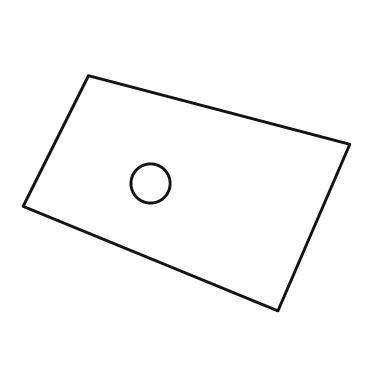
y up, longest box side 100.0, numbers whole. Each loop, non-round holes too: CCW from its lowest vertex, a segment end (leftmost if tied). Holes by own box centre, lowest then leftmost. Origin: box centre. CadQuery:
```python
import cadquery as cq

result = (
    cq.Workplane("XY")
    .moveTo(28.0, -36.0)
    .lineTo(50.0, 15.0)
    .lineTo(-30.0, 36.0)
    .lineTo(-50.0, -4.0)
    .close()
    .moveTo(-11.0, 3.0)
    .circle(6.0)
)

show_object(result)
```